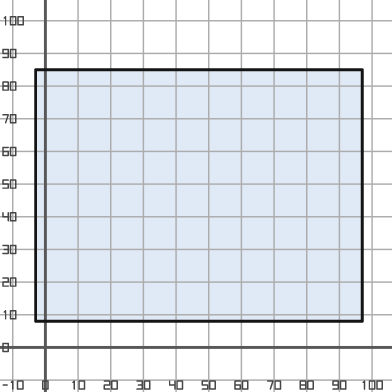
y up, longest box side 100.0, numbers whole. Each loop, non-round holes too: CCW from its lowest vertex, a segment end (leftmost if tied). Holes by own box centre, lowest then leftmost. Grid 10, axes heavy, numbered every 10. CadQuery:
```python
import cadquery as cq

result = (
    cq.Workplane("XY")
    .moveTo(-3.0, 8.0)
    .lineTo(97.0, 8.0)
    .lineTo(97.0, 85.0)
    .lineTo(-3.0, 85.0)
    .close()
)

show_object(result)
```